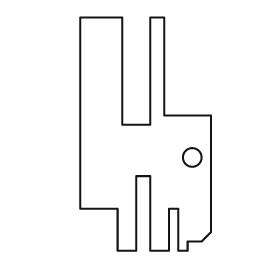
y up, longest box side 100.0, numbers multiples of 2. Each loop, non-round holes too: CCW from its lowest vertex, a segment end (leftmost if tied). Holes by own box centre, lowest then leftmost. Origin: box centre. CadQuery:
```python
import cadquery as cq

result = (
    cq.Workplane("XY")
    .moveTo(-12.0, -50.0)
    .lineTo(-4.0, -50.0)
    .lineTo(-4.0, -18.0)
    .lineTo(2.0, -18.0)
    .lineTo(2.0, -50.0)
    .lineTo(10.0, -50.0)
    .lineTo(10.0, -32.0)
    .lineTo(14.0, -32.0)
    .lineTo(14.0, -50.0)
    .lineTo(18.0, -50.0)
    .lineTo(18.0, -46.0)
    .lineTo(24.0, -46.0)
    .lineTo(28.0, -42.0)
    .lineTo(28.0, 8.0)
    .lineTo(8.0, 8.0)
    .lineTo(8.0, 50.0)
    .lineTo(2.0, 50.0)
    .lineTo(2.0, 4.0)
    .lineTo(-10.0, 4.0)
    .lineTo(-10.0, 50.0)
    .lineTo(-28.0, 50.0)
    .lineTo(-28.0, -32.0)
    .lineTo(-12.0, -32.0)
    .close()
    .moveTo(20.0, -10.0)
    .circle(4.0)
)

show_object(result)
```